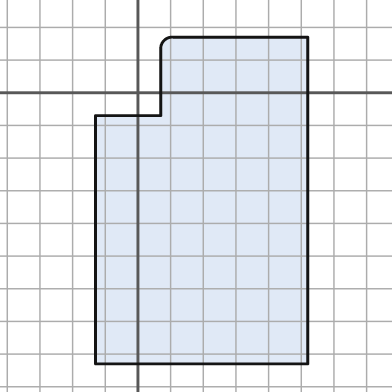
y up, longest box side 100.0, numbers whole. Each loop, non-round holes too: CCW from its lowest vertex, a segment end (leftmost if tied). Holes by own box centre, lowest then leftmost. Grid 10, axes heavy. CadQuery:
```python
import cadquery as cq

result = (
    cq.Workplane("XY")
    .moveTo(-13.0, -83.0)
    .lineTo(52.0, -83.0)
    .lineTo(52.0, 17.0)
    .lineTo(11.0, 17.0)
    .threePointArc((8.0, 16.0), (7.0, 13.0))
    .lineTo(7.0, -7.0)
    .lineTo(-13.0, -7.0)
    .close()
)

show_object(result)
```